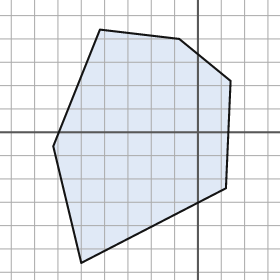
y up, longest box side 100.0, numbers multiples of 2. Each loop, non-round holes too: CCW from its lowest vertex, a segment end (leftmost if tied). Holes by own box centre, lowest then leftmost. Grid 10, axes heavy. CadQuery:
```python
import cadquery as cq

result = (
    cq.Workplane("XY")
    .moveTo(-50.0, -56.0)
    .lineTo(12.0, -24.0)
    .lineTo(14.0, 22.0)
    .lineTo(-8.0, 40.0)
    .lineTo(-42.0, 44.0)
    .lineTo(-62.0, -6.0)
    .close()
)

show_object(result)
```